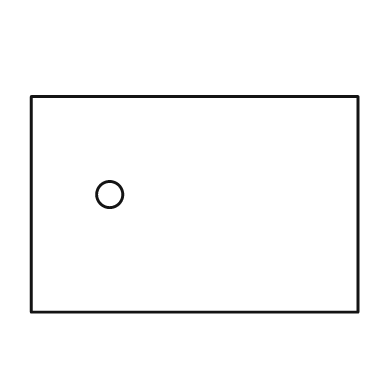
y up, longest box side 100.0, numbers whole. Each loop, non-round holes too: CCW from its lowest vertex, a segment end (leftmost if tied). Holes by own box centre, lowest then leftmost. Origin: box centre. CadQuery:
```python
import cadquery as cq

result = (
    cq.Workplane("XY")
    .moveTo(-50.0, -33.0)
    .lineTo(50.0, -33.0)
    .lineTo(50.0, 33.0)
    .lineTo(-50.0, 33.0)
    .close()
    .moveTo(-26.0, 3.0)
    .circle(4.0)
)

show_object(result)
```